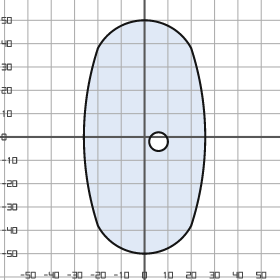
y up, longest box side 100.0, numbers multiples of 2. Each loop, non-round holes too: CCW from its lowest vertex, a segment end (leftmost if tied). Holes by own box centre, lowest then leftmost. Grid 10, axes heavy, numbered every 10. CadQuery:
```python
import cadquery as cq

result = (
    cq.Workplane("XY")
    .moveTo(-20.0, -38.0)
    .threePointArc((0.0, -50.0), (20.0, -38.0))
    .threePointArc((26.0, 0.0), (20.0, 38.0))
    .threePointArc((0.0, 50.0), (-20.0, 38.0))
    .threePointArc((-26.0, 0.0), (-20.0, -38.0))
    .close()
    .moveTo(6.0, -2.0)
    .circle(4.0)
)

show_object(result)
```